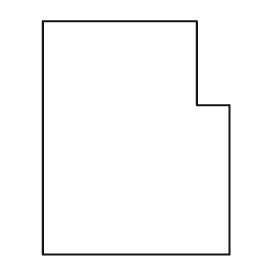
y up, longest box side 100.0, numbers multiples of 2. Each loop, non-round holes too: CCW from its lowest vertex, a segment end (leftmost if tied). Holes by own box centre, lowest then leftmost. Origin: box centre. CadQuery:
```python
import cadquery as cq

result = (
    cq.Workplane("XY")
    .moveTo(-40.0, -50.0)
    .lineTo(40.0, -50.0)
    .lineTo(40.0, 14.0)
    .lineTo(26.0, 14.0)
    .lineTo(26.0, 50.0)
    .lineTo(-40.0, 50.0)
    .close()
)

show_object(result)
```